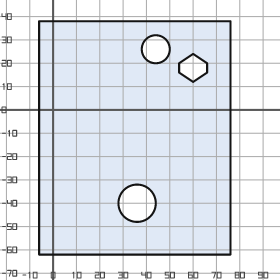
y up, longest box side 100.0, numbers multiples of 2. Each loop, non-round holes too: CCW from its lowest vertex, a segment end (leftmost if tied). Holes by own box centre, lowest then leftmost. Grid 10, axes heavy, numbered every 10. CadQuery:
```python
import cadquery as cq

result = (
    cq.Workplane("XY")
    .moveTo(-6.0, -62.0)
    .lineTo(76.0, -62.0)
    .lineTo(76.0, 38.0)
    .lineTo(-6.0, 38.0)
    .close()
    .moveTo(36.0, -40.0)
    .circle(8.0)
    .moveTo(60.0, 12.0)
    .lineTo(66.0, 16.0)
    .lineTo(66.0, 20.0)
    .lineTo(60.0, 24.0)
    .lineTo(54.0, 20.0)
    .lineTo(54.0, 16.0)
    .close()
    .moveTo(44.0, 26.0)
    .circle(6.0)
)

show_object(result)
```